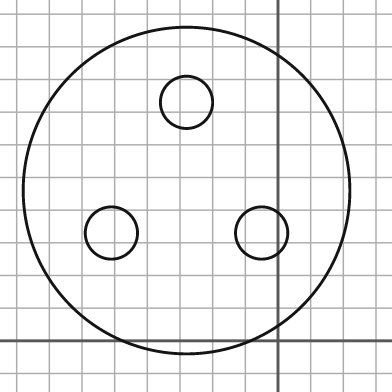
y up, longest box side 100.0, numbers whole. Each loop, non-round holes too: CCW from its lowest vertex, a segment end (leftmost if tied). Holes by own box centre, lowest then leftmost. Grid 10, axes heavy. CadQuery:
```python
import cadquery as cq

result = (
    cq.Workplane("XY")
    .moveTo(-28.0, 46.0)
    .circle(50.0)
    .moveTo(-51.0, 33.0)
    .circle(8.0)
    .moveTo(-5.0, 33.0)
    .circle(8.0)
    .moveTo(-28.0, 73.0)
    .circle(8.0)
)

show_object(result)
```